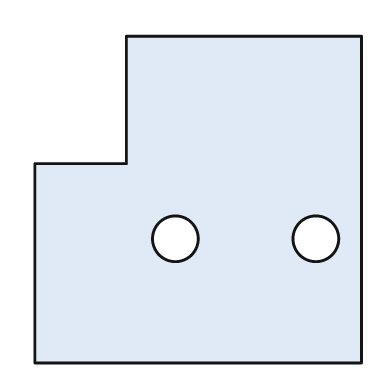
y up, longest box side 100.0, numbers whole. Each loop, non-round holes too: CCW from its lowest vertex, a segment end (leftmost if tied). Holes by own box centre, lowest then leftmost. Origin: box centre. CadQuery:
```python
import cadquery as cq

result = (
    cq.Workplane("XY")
    .moveTo(-50.0, -50.0)
    .lineTo(50.0, -50.0)
    .lineTo(50.0, 50.0)
    .lineTo(-22.0, 50.0)
    .lineTo(-22.0, 11.0)
    .lineTo(-50.0, 11.0)
    .close()
    .moveTo(-7.0, -12.0)
    .circle(7.0)
    .moveTo(36.0, -12.0)
    .circle(7.0)
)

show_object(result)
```